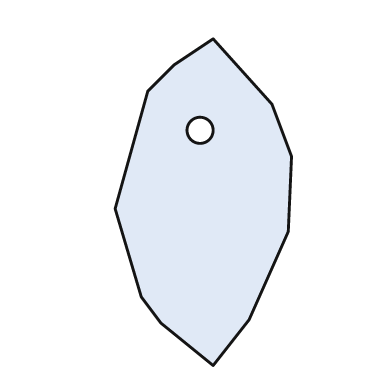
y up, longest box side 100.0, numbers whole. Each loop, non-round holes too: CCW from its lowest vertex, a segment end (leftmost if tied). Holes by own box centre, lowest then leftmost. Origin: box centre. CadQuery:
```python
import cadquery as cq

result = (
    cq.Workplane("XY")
    .moveTo(3.0, -50.0)
    .lineTo(14.0, -36.0)
    .lineTo(26.0, -9.0)
    .lineTo(27.0, 14.0)
    .lineTo(21.0, 30.0)
    .lineTo(3.0, 50.0)
    .lineTo(-9.0, 42.0)
    .lineTo(-17.0, 34.0)
    .lineTo(-27.0, -2.0)
    .lineTo(-19.0, -29.0)
    .lineTo(-13.0, -37.0)
    .close()
    .moveTo(-1.0, 22.0)
    .circle(4.0)
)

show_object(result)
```